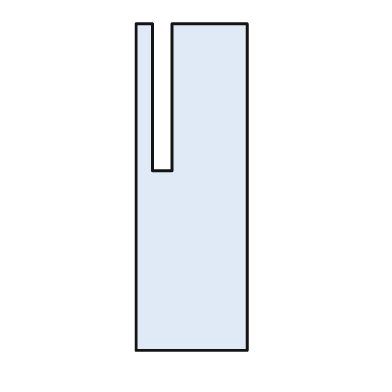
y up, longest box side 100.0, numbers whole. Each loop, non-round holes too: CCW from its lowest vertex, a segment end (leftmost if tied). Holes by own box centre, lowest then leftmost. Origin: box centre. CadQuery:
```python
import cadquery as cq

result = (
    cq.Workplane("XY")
    .moveTo(-17.0, -50.0)
    .lineTo(17.0, -50.0)
    .lineTo(17.0, 50.0)
    .lineTo(-6.0, 50.0)
    .lineTo(-6.0, 5.0)
    .lineTo(-12.0, 5.0)
    .lineTo(-12.0, 50.0)
    .lineTo(-17.0, 50.0)
    .close()
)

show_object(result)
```